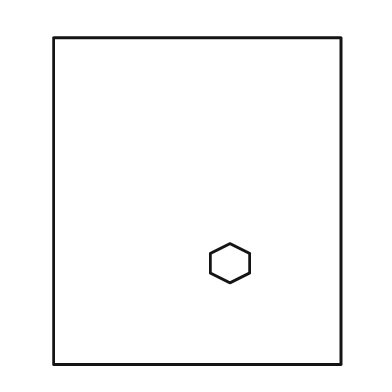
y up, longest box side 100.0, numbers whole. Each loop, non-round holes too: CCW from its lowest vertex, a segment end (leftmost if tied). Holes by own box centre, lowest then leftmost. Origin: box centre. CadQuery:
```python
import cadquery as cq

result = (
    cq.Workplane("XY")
    .moveTo(-44.0, -50.0)
    .lineTo(44.0, -50.0)
    .lineTo(44.0, 50.0)
    .lineTo(-44.0, 50.0)
    .close()
    .moveTo(10.0, -25.0)
    .lineTo(16.0, -22.0)
    .lineTo(16.0, -16.0)
    .lineTo(10.0, -13.0)
    .lineTo(4.0, -16.0)
    .lineTo(4.0, -22.0)
    .close()
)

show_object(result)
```